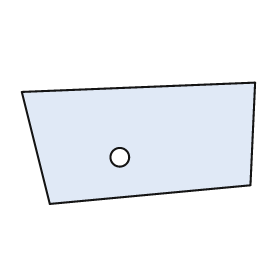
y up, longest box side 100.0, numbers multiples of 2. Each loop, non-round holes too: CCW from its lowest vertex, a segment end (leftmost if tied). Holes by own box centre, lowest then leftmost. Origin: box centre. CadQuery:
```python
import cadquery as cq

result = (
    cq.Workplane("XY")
    .moveTo(-38.0, -26.0)
    .lineTo(48.0, -18.0)
    .lineTo(50.0, 26.0)
    .lineTo(-50.0, 22.0)
    .close()
    .moveTo(-8.0, -6.0)
    .circle(4.0)
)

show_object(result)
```